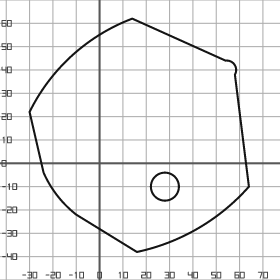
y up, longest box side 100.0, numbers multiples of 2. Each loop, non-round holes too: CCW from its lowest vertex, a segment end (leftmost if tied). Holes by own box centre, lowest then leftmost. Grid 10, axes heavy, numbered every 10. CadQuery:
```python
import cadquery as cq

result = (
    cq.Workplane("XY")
    .moveTo(16.0, -38.0)
    .threePointArc((42.0, -28.0), (64.0, -10.0))
    .lineTo(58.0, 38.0)
    .threePointArc((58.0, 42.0), (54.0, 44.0))
    .lineTo(14.0, 62.0)
    .threePointArc((-12.0, 46.0), (-30.0, 22.0))
    .lineTo(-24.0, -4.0)
    .threePointArc((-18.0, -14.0), (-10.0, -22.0))
    .close()
    .moveTo(28.0, -10.0)
    .circle(6.0)
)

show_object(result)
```